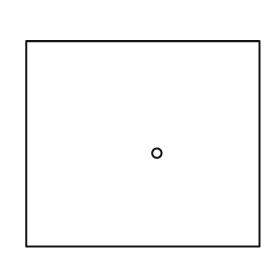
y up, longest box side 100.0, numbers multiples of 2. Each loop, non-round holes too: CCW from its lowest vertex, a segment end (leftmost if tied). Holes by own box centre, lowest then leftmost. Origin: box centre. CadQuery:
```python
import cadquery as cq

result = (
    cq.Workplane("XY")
    .moveTo(-50.0, -44.0)
    .lineTo(50.0, -44.0)
    .lineTo(50.0, 44.0)
    .lineTo(-50.0, 44.0)
    .close()
    .moveTo(6.0, -4.0)
    .circle(2.0)
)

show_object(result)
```